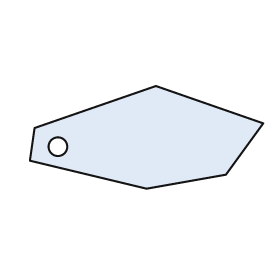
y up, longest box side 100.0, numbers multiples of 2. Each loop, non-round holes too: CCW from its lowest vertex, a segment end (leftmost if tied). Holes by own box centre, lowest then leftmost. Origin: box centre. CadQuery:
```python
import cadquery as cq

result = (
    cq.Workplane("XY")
    .moveTo(0.0, -22.0)
    .lineTo(34.0, -16.0)
    .lineTo(50.0, 6.0)
    .lineTo(4.0, 22.0)
    .lineTo(-48.0, 4.0)
    .lineTo(-50.0, -10.0)
    .close()
    .moveTo(-38.0, -4.0)
    .circle(4.0)
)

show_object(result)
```